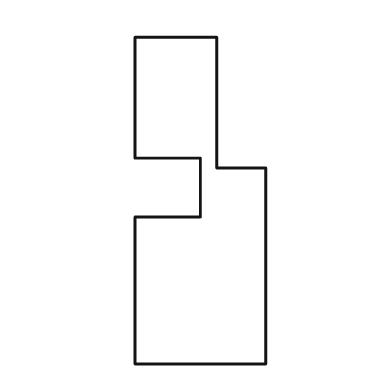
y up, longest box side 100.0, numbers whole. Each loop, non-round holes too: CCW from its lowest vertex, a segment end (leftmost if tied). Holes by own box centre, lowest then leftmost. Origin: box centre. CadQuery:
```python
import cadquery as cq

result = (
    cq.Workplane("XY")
    .moveTo(-20.0, -50.0)
    .lineTo(20.0, -50.0)
    .lineTo(20.0, 10.0)
    .lineTo(5.0, 10.0)
    .lineTo(5.0, 50.0)
    .lineTo(-20.0, 50.0)
    .lineTo(-20.0, 13.0)
    .lineTo(0.0, 13.0)
    .lineTo(0.0, -5.0)
    .lineTo(-20.0, -5.0)
    .close()
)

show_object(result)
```